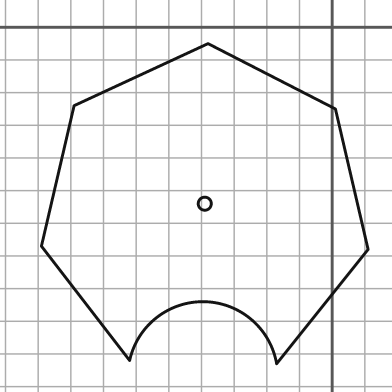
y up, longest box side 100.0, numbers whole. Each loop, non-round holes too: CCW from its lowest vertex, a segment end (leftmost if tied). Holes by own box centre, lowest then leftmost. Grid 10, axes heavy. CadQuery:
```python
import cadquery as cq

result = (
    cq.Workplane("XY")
    .moveTo(-17.0, -103.0)
    .lineTo(11.0, -68.0)
    .lineTo(1.0, -25.0)
    .lineTo(-38.0, -5.0)
    .lineTo(-79.0, -24.0)
    .lineTo(-89.0, -67.0)
    .lineTo(-62.0, -102.0)
    .threePointArc((-39.0, -84.0), (-17.0, -103.0))
    .close()
    .moveTo(-39.0, -54.0)
    .circle(2.0)
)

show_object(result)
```